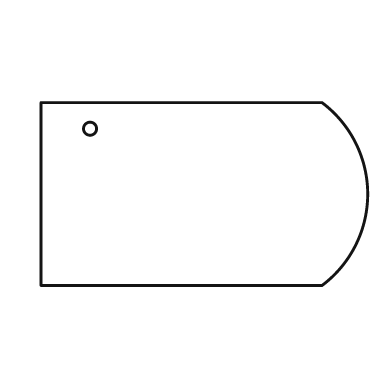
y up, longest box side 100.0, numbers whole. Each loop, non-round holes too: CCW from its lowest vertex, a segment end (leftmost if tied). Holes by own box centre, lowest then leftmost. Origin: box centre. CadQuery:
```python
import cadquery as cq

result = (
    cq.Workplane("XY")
    .moveTo(-50.0, -28.0)
    .lineTo(36.0, -28.0)
    .threePointArc((50.0, 0.0), (36.0, 28.0))
    .lineTo(-50.0, 28.0)
    .close()
    .moveTo(-35.0, 20.0)
    .circle(2.0)
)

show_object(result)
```